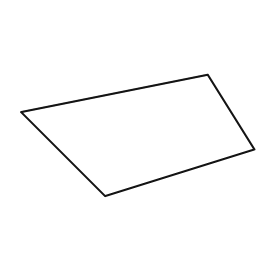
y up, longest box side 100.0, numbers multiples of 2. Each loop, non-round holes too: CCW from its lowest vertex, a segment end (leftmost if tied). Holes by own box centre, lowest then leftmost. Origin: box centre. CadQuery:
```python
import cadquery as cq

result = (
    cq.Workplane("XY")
    .moveTo(-14.0, -26.0)
    .lineTo(50.0, -6.0)
    .lineTo(30.0, 26.0)
    .lineTo(-50.0, 10.0)
    .close()
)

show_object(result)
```